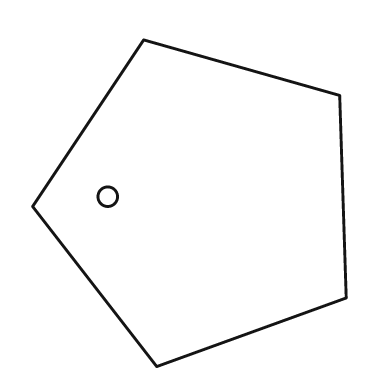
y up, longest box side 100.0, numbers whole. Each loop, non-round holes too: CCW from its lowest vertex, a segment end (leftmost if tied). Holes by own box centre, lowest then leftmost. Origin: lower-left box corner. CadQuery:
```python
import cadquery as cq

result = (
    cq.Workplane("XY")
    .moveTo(38.0, 0.0)
    .lineTo(96.0, 21.0)
    .lineTo(94.0, 83.0)
    .lineTo(34.0, 100.0)
    .lineTo(0.0, 49.0)
    .close()
    .moveTo(23.0, 52.0)
    .circle(3.0)
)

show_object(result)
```